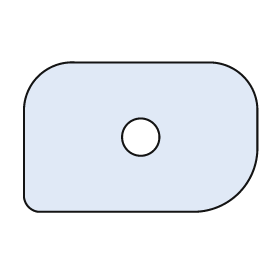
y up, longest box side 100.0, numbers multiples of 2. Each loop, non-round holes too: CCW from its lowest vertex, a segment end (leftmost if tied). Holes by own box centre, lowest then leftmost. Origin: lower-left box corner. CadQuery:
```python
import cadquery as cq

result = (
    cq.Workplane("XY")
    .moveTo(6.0, 0.0)
    .lineTo(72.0, 0.0)
    .threePointArc((92.0, 8.0), (100.0, 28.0))
    .lineTo(100.0, 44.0)
    .threePointArc((94.0, 58.0), (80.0, 64.0))
    .lineTo(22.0, 64.0)
    .threePointArc((6.0, 58.0), (0.0, 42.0))
    .lineTo(0.0, 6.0)
    .threePointArc((2.0, 2.0), (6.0, 0.0))
    .close()
    .moveTo(50.0, 32.0)
    .circle(8.0)
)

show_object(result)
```